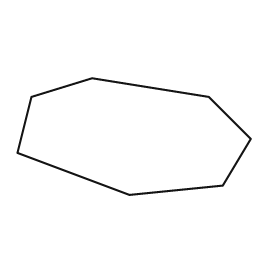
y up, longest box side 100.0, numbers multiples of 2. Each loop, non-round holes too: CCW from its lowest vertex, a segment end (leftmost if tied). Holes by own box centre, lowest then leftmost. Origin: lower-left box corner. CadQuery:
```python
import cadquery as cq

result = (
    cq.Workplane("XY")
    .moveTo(48.0, 0.0)
    .lineTo(88.0, 4.0)
    .lineTo(100.0, 24.0)
    .lineTo(82.0, 42.0)
    .lineTo(32.0, 50.0)
    .lineTo(6.0, 42.0)
    .lineTo(0.0, 18.0)
    .close()
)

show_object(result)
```